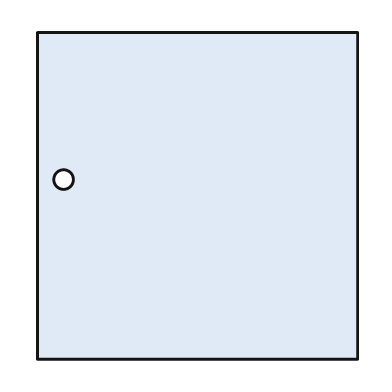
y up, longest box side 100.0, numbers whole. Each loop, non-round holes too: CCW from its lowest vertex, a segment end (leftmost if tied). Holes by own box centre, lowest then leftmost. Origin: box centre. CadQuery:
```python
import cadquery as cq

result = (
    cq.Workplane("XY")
    .moveTo(-49.0, -50.0)
    .lineTo(49.0, -50.0)
    .lineTo(49.0, 50.0)
    .lineTo(-49.0, 50.0)
    .close()
    .moveTo(-41.0, 5.0)
    .circle(3.0)
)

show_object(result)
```